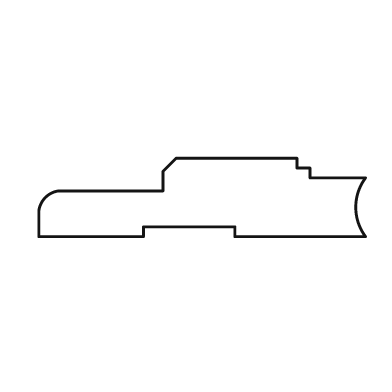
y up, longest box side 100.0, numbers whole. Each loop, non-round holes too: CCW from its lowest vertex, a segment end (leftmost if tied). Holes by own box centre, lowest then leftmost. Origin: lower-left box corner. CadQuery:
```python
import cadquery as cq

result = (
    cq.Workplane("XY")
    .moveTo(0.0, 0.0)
    .lineTo(32.0, 0.0)
    .lineTo(32.0, 3.0)
    .lineTo(60.0, 3.0)
    .lineTo(60.0, 0.0)
    .lineTo(100.0, 0.0)
    .threePointArc((97.0, 9.0), (100.0, 18.0))
    .lineTo(83.0, 18.0)
    .lineTo(83.0, 21.0)
    .lineTo(79.0, 21.0)
    .lineTo(79.0, 24.0)
    .lineTo(42.0, 24.0)
    .lineTo(38.0, 20.0)
    .lineTo(38.0, 14.0)
    .lineTo(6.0, 14.0)
    .threePointArc((2.0, 12.0), (0.0, 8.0))
    .close()
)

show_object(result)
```